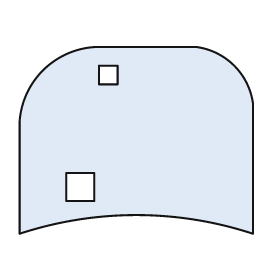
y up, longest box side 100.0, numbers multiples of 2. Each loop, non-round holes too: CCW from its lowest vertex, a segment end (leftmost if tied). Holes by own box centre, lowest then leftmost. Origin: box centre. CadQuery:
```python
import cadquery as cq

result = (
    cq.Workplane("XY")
    .moveTo(-50.0, -40.0)
    .threePointArc((0.0, -32.0), (50.0, -40.0))
    .lineTo(50.0, 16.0)
    .threePointArc((42.0, 32.0), (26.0, 40.0))
    .lineTo(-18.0, 40.0)
    .threePointArc((-40.0, 30.0), (-50.0, 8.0))
    .close()
    .moveTo(-30.0, -26.0)
    .lineTo(-18.0, -26.0)
    .lineTo(-18.0, -14.0)
    .lineTo(-30.0, -14.0)
    .close()
    .moveTo(-16.0, 24.0)
    .lineTo(-8.0, 24.0)
    .lineTo(-8.0, 32.0)
    .lineTo(-16.0, 32.0)
    .close()
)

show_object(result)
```